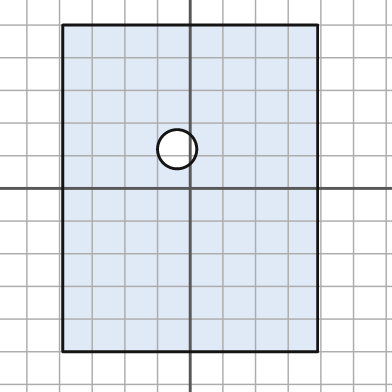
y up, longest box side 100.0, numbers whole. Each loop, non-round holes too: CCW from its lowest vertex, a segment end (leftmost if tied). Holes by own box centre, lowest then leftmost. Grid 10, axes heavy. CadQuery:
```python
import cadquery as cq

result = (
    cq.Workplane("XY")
    .moveTo(-39.0, -50.0)
    .lineTo(39.0, -50.0)
    .lineTo(39.0, 50.0)
    .lineTo(-39.0, 50.0)
    .close()
    .moveTo(-4.0, 12.0)
    .circle(6.0)
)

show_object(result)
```